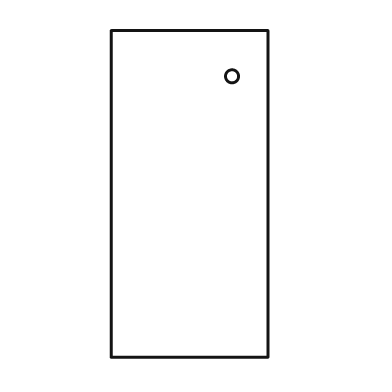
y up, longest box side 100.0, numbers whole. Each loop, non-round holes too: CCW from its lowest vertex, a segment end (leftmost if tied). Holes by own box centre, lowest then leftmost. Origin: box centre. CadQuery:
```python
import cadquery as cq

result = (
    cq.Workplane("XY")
    .moveTo(-24.0, -50.0)
    .lineTo(24.0, -50.0)
    .lineTo(24.0, 50.0)
    .lineTo(-24.0, 50.0)
    .close()
    .moveTo(13.0, 36.0)
    .circle(2.0)
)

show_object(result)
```